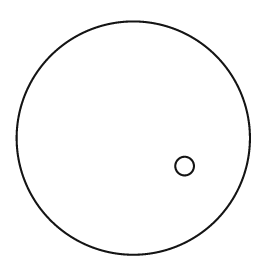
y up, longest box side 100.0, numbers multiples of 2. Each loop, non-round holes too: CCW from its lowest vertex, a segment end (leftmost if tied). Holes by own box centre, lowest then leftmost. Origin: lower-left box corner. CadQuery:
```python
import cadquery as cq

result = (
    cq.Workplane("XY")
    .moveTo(50.0, 50.0)
    .circle(50.0)
    .moveTo(72.0, 38.0)
    .circle(4.0)
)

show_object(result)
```